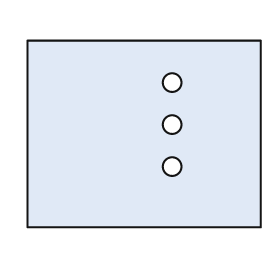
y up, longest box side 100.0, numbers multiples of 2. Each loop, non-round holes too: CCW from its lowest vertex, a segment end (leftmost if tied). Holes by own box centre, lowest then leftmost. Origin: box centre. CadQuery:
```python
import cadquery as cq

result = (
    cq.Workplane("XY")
    .moveTo(-50.0, -40.0)
    .lineTo(50.0, -40.0)
    .lineTo(50.0, 40.0)
    .lineTo(-50.0, 40.0)
    .close()
    .moveTo(12.0, -14.0)
    .circle(4.0)
    .moveTo(12.0, 4.0)
    .circle(4.0)
    .moveTo(12.0, 22.0)
    .circle(4.0)
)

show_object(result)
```